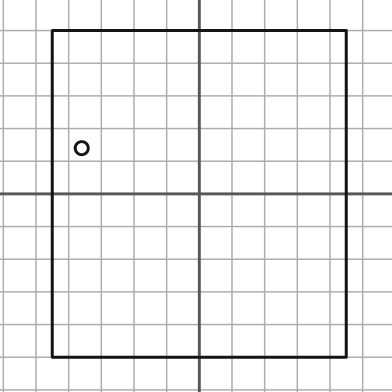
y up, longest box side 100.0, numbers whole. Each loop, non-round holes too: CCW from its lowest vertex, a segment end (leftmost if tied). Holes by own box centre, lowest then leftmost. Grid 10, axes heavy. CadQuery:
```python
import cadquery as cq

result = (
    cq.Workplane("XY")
    .moveTo(-45.0, -50.0)
    .lineTo(45.0, -50.0)
    .lineTo(45.0, 50.0)
    .lineTo(-45.0, 50.0)
    .close()
    .moveTo(-36.0, 14.0)
    .circle(2.0)
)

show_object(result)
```